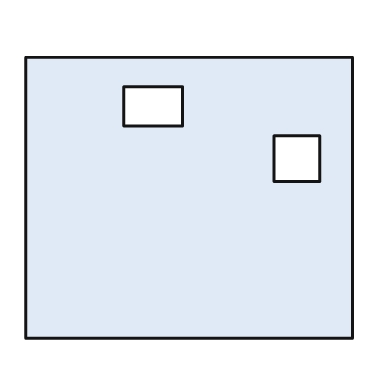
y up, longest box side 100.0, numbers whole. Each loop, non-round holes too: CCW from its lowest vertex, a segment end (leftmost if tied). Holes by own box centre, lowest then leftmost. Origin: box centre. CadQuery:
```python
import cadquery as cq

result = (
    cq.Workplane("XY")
    .moveTo(-50.0, -43.0)
    .lineTo(50.0, -43.0)
    .lineTo(50.0, 43.0)
    .lineTo(-50.0, 43.0)
    .close()
    .moveTo(26.0, 5.0)
    .lineTo(40.0, 5.0)
    .lineTo(40.0, 19.0)
    .lineTo(26.0, 19.0)
    .close()
    .moveTo(-20.0, 22.0)
    .lineTo(-2.0, 22.0)
    .lineTo(-2.0, 34.0)
    .lineTo(-20.0, 34.0)
    .close()
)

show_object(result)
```